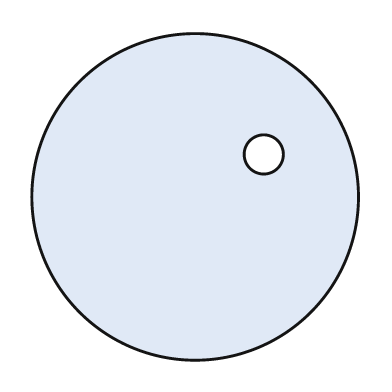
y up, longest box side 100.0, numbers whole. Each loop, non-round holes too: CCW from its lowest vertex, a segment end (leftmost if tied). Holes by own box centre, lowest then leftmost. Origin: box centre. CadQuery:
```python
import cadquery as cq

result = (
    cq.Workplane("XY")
    .moveTo(0.0, 0.0)
    .circle(50.0)
    .moveTo(21.0, 13.0)
    .circle(6.0)
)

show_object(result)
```